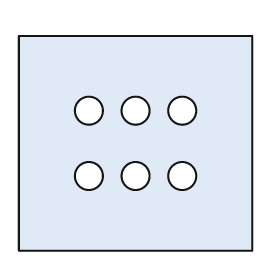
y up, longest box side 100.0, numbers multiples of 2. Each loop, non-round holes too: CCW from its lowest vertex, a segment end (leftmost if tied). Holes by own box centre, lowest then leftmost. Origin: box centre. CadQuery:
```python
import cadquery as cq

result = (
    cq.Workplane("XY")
    .moveTo(-50.0, -46.0)
    .lineTo(50.0, -46.0)
    .lineTo(50.0, 46.0)
    .lineTo(-50.0, 46.0)
    .close()
    .moveTo(-20.0, -14.0)
    .circle(6.0)
    .moveTo(0.0, -14.0)
    .circle(6.0)
    .moveTo(20.0, -14.0)
    .circle(6.0)
    .moveTo(-20.0, 14.0)
    .circle(6.0)
    .moveTo(0.0, 14.0)
    .circle(6.0)
    .moveTo(20.0, 14.0)
    .circle(6.0)
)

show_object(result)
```